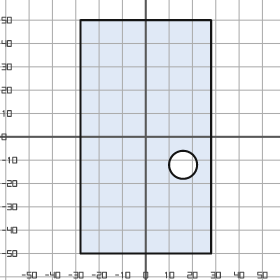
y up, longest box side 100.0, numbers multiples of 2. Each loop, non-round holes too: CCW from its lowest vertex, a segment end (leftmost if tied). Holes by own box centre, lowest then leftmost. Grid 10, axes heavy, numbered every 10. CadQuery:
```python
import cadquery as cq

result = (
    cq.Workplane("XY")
    .moveTo(-28.0, -50.0)
    .lineTo(28.0, -50.0)
    .lineTo(28.0, 50.0)
    .lineTo(-28.0, 50.0)
    .close()
    .moveTo(16.0, -12.0)
    .circle(6.0)
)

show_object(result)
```